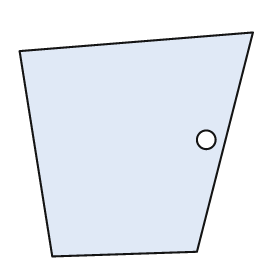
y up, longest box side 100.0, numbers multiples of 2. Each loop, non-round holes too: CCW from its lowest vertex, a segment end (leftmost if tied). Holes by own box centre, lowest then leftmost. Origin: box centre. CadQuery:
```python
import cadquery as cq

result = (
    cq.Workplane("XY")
    .moveTo(-36.0, -48.0)
    .lineTo(26.0, -46.0)
    .lineTo(50.0, 48.0)
    .lineTo(-50.0, 40.0)
    .close()
    .moveTo(30.0, 2.0)
    .circle(4.0)
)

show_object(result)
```